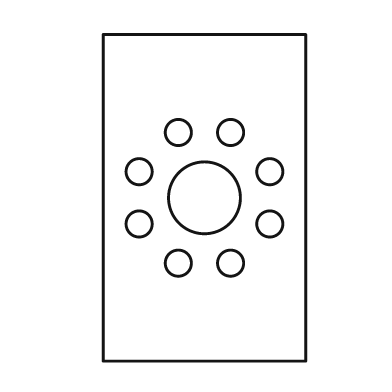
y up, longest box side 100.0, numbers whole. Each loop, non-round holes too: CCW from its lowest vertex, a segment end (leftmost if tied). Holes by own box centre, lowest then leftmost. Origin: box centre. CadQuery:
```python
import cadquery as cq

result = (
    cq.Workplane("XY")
    .moveTo(-31.0, -50.0)
    .lineTo(31.0, -50.0)
    .lineTo(31.0, 50.0)
    .lineTo(-31.0, 50.0)
    .close()
    .moveTo(-8.0, -20.0)
    .circle(4.0)
    .moveTo(8.0, -20.0)
    .circle(4.0)
    .moveTo(-20.0, -8.0)
    .circle(4.0)
    .moveTo(20.0, -8.0)
    .circle(4.0)
    .moveTo(0.0, 0.0)
    .circle(11.0)
    .moveTo(-20.0, 8.0)
    .circle(4.0)
    .moveTo(20.0, 8.0)
    .circle(4.0)
    .moveTo(-8.0, 20.0)
    .circle(4.0)
    .moveTo(8.0, 20.0)
    .circle(4.0)
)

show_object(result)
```